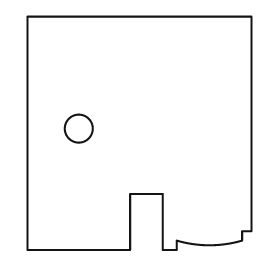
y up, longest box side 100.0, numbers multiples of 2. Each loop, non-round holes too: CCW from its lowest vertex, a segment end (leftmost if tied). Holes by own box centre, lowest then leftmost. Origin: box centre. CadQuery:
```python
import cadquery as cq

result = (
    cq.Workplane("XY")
    .moveTo(-48.0, -50.0)
    .lineTo(-4.0, -50.0)
    .lineTo(-4.0, -26.0)
    .lineTo(10.0, -26.0)
    .lineTo(10.0, -50.0)
    .lineTo(16.0, -50.0)
    .lineTo(16.0, -46.0)
    .threePointArc((30.0, -48.0), (44.0, -46.0))
    .lineTo(44.0, -42.0)
    .lineTo(48.0, -42.0)
    .lineTo(48.0, 50.0)
    .lineTo(-48.0, 50.0)
    .close()
    .moveTo(-26.0, 2.0)
    .circle(6.0)
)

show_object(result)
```